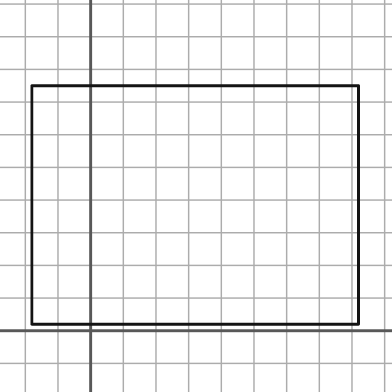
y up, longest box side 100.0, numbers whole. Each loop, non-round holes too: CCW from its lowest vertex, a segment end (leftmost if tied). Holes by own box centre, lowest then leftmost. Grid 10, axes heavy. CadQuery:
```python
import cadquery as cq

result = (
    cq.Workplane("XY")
    .moveTo(-18.0, 2.0)
    .lineTo(82.0, 2.0)
    .lineTo(82.0, 75.0)
    .lineTo(-18.0, 75.0)
    .close()
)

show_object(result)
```